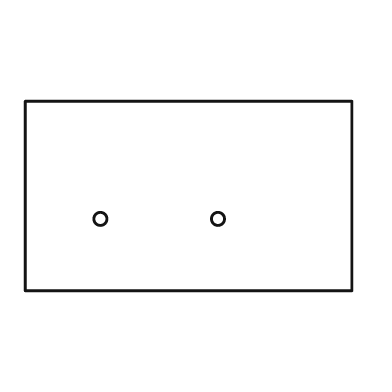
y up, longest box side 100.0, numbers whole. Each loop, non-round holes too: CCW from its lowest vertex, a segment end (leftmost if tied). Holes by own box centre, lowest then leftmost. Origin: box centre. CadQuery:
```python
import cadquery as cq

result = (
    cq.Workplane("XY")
    .moveTo(-50.0, -29.0)
    .lineTo(50.0, -29.0)
    .lineTo(50.0, 29.0)
    .lineTo(-50.0, 29.0)
    .close()
    .moveTo(-27.0, -7.0)
    .circle(2.0)
    .moveTo(9.0, -7.0)
    .circle(2.0)
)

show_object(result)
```